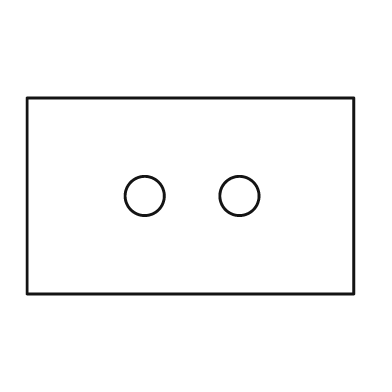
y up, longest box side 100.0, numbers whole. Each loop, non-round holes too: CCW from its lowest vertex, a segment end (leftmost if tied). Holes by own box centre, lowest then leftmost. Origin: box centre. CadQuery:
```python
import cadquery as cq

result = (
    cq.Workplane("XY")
    .moveTo(-50.0, -30.0)
    .lineTo(50.0, -30.0)
    .lineTo(50.0, 30.0)
    .lineTo(-50.0, 30.0)
    .close()
    .moveTo(-14.0, 0.0)
    .circle(6.0)
    .moveTo(15.0, 0.0)
    .circle(6.0)
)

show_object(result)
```